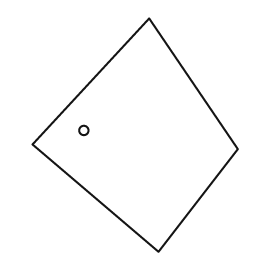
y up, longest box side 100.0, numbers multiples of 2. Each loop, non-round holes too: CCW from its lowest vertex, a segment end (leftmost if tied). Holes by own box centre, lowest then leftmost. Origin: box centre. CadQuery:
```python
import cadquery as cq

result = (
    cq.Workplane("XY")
    .moveTo(10.0, -50.0)
    .lineTo(44.0, -6.0)
    .lineTo(6.0, 50.0)
    .lineTo(-44.0, -4.0)
    .close()
    .moveTo(-22.0, 2.0)
    .circle(2.0)
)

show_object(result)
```